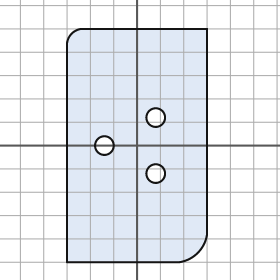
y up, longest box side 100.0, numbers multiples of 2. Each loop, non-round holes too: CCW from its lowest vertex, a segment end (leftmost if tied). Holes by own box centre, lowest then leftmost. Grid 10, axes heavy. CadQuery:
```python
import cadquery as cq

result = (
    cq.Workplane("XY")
    .moveTo(-30.0, -50.0)
    .lineTo(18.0, -50.0)
    .threePointArc((26.0, -46.0), (30.0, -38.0))
    .lineTo(30.0, 50.0)
    .lineTo(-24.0, 50.0)
    .threePointArc((-28.0, 48.0), (-30.0, 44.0))
    .close()
    .moveTo(8.0, -12.0)
    .circle(4.0)
    .moveTo(-14.0, 0.0)
    .circle(4.0)
    .moveTo(8.0, 12.0)
    .circle(4.0)
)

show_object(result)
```